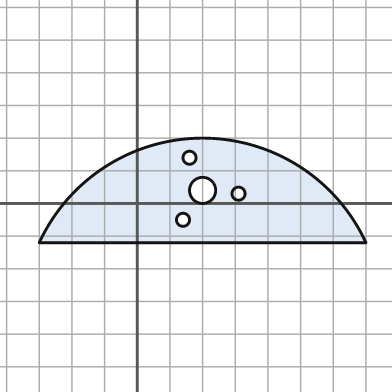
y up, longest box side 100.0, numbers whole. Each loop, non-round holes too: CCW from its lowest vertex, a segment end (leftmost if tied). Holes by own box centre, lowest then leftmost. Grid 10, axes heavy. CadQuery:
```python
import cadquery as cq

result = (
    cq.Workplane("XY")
    .moveTo(-30.0, -12.0)
    .lineTo(70.0, -12.0)
    .threePointArc((20.0, 20.0), (-30.0, -12.0))
    .close()
    .moveTo(14.0, -5.0)
    .circle(2.0)
    .moveTo(31.0, 3.0)
    .circle(2.0)
    .moveTo(20.0, 4.0)
    .circle(4.0)
    .moveTo(16.0, 14.0)
    .circle(2.0)
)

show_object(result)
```